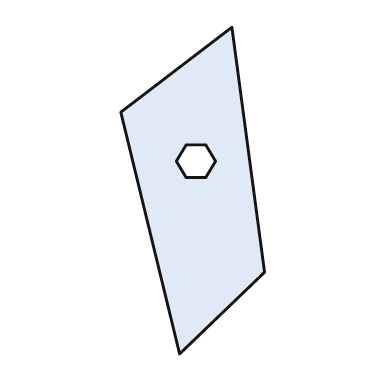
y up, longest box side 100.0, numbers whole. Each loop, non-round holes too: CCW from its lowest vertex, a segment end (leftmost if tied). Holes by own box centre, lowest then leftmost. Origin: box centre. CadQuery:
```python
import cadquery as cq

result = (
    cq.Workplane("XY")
    .moveTo(-4.0, -50.0)
    .lineTo(22.0, -25.0)
    .lineTo(12.0, 50.0)
    .lineTo(-22.0, 24.0)
    .close()
    .moveTo(-2.0, 4.0)
    .lineTo(4.0, 4.0)
    .lineTo(7.0, 9.0)
    .lineTo(4.0, 14.0)
    .lineTo(-2.0, 14.0)
    .lineTo(-5.0, 9.0)
    .close()
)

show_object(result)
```